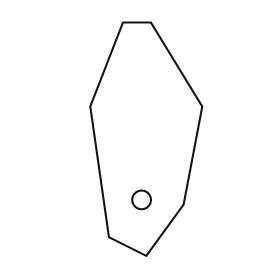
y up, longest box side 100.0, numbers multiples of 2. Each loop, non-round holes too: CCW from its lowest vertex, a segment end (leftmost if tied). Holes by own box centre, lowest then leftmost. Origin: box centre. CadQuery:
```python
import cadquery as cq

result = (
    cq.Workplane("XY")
    .moveTo(0.0, -50.0)
    .lineTo(16.0, -28.0)
    .lineTo(24.0, 14.0)
    .lineTo(2.0, 50.0)
    .lineTo(-10.0, 50.0)
    .lineTo(-24.0, 14.0)
    .lineTo(-16.0, -42.0)
    .close()
    .moveTo(-2.0, -26.0)
    .circle(4.0)
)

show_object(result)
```